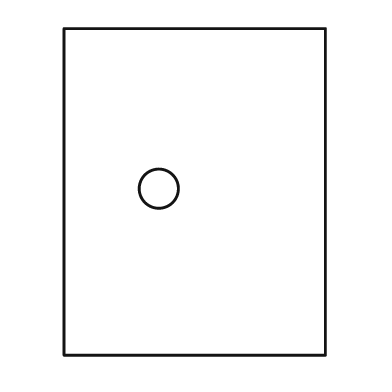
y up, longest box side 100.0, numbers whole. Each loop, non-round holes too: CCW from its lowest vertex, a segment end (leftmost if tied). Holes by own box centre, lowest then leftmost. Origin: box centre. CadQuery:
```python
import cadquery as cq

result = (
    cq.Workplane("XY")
    .moveTo(-40.0, -50.0)
    .lineTo(40.0, -50.0)
    .lineTo(40.0, 50.0)
    .lineTo(-40.0, 50.0)
    .close()
    .moveTo(-11.0, 1.0)
    .circle(6.0)
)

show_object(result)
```